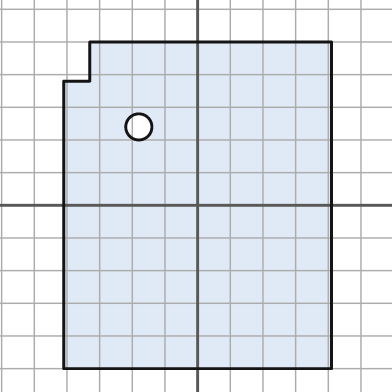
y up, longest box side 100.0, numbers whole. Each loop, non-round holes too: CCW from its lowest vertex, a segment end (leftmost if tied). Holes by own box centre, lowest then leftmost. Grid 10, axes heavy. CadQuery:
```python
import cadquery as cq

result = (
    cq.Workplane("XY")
    .moveTo(-41.0, -50.0)
    .lineTo(41.0, -50.0)
    .lineTo(41.0, 50.0)
    .lineTo(-33.0, 50.0)
    .lineTo(-33.0, 38.0)
    .lineTo(-41.0, 38.0)
    .close()
    .moveTo(-18.0, 24.0)
    .circle(4.0)
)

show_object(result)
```